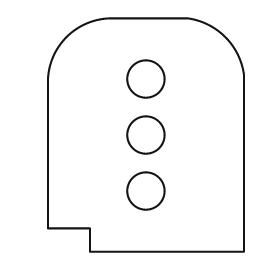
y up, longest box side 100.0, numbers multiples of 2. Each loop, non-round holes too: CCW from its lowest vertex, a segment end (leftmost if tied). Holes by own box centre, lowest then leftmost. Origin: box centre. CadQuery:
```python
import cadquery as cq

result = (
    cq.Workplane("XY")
    .moveTo(-24.0, -50.0)
    .lineTo(42.0, -50.0)
    .lineTo(42.0, 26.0)
    .threePointArc((34.0, 42.0), (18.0, 50.0))
    .lineTo(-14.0, 50.0)
    .threePointArc((-34.0, 42.0), (-42.0, 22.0))
    .lineTo(-42.0, -40.0)
    .lineTo(-24.0, -40.0)
    .close()
    .moveTo(0.0, -24.0)
    .circle(8.0)
    .moveTo(0.0, 0.0)
    .circle(8.0)
    .moveTo(0.0, 24.0)
    .circle(8.0)
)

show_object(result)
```